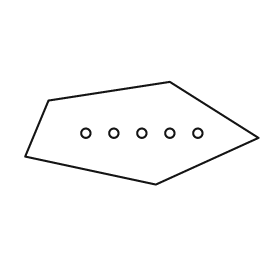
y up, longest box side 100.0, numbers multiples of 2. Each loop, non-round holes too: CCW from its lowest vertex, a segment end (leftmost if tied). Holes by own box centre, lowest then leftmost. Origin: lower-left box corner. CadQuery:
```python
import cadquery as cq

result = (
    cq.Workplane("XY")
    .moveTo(56.0, 0.0)
    .lineTo(100.0, 20.0)
    .lineTo(62.0, 44.0)
    .lineTo(10.0, 36.0)
    .lineTo(0.0, 12.0)
    .close()
    .moveTo(26.0, 22.0)
    .circle(2.0)
    .moveTo(38.0, 22.0)
    .circle(2.0)
    .moveTo(50.0, 22.0)
    .circle(2.0)
    .moveTo(62.0, 22.0)
    .circle(2.0)
    .moveTo(74.0, 22.0)
    .circle(2.0)
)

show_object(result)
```